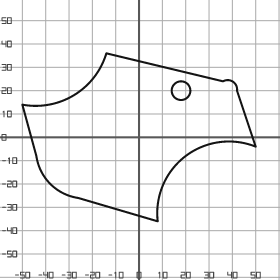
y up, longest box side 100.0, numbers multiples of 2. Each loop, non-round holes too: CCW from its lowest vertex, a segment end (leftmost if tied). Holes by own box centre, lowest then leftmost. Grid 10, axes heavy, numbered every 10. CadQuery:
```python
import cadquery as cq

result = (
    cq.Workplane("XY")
    .moveTo(8.0, -36.0)
    .threePointArc((20.0, -8.0), (50.0, -4.0))
    .lineTo(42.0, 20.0)
    .threePointArc((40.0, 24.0), (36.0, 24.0))
    .lineTo(-14.0, 36.0)
    .threePointArc((-28.0, 18.0), (-50.0, 14.0))
    .lineTo(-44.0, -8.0)
    .threePointArc((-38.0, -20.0), (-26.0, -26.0))
    .close()
    .moveTo(18.0, 20.0)
    .circle(4.0)
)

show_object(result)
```